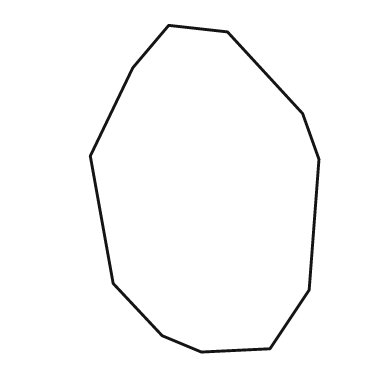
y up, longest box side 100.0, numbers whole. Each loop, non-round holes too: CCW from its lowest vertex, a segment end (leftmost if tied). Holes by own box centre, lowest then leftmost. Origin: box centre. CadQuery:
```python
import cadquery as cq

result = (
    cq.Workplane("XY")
    .moveTo(-1.0, -50.0)
    .lineTo(20.0, -49.0)
    .lineTo(32.0, -31.0)
    .lineTo(35.0, 9.0)
    .lineTo(30.0, 23.0)
    .lineTo(7.0, 48.0)
    .lineTo(-11.0, 50.0)
    .lineTo(-22.0, 37.0)
    .lineTo(-35.0, 10.0)
    .lineTo(-28.0, -29.0)
    .lineTo(-13.0, -45.0)
    .close()
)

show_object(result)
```